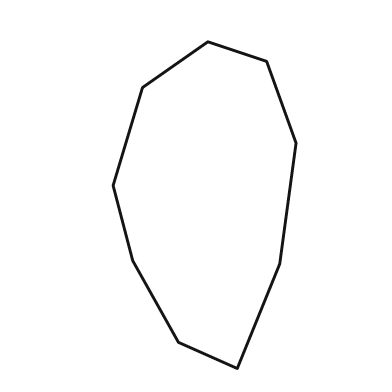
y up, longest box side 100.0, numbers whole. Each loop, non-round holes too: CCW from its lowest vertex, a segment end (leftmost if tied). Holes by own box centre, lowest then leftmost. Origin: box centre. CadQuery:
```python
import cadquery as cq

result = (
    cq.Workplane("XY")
    .moveTo(10.0, -50.0)
    .lineTo(23.0, -18.0)
    .lineTo(28.0, 19.0)
    .lineTo(19.0, 44.0)
    .lineTo(1.0, 50.0)
    .lineTo(-19.0, 36.0)
    .lineTo(-28.0, 6.0)
    .lineTo(-22.0, -17.0)
    .lineTo(-8.0, -42.0)
    .close()
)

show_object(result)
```